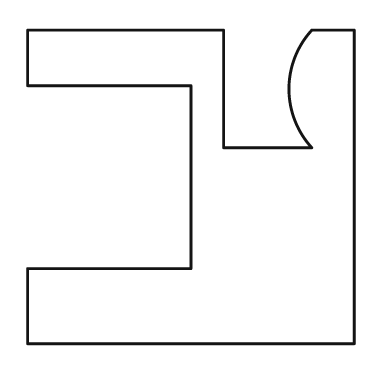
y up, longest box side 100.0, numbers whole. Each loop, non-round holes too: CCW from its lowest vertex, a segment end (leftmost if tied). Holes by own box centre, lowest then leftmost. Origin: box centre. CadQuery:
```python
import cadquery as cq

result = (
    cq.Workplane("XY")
    .moveTo(-50.0, -48.0)
    .lineTo(50.0, -48.0)
    .lineTo(50.0, 48.0)
    .lineTo(37.0, 48.0)
    .threePointArc((30.0, 30.0), (37.0, 12.0))
    .lineTo(10.0, 12.0)
    .lineTo(10.0, 48.0)
    .lineTo(-50.0, 48.0)
    .lineTo(-50.0, 31.0)
    .lineTo(0.0, 31.0)
    .lineTo(0.0, -25.0)
    .lineTo(-50.0, -25.0)
    .close()
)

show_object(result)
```